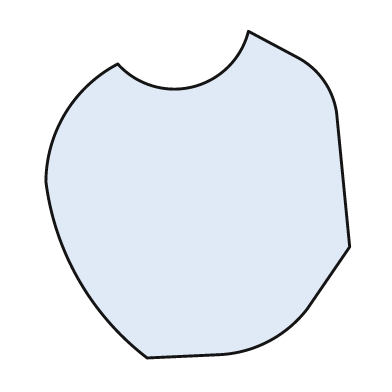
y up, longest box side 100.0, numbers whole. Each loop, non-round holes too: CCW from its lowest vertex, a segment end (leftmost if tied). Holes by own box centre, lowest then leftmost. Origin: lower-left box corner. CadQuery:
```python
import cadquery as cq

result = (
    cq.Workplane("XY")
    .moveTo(31.0, 0.0)
    .lineTo(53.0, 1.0)
    .threePointArc((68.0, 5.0), (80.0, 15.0))
    .lineTo(93.0, 34.0)
    .lineTo(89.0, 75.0)
    .threePointArc((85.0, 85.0), (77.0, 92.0))
    .lineTo(62.0, 100.0)
    .threePointArc((45.0, 83.0), (22.0, 90.0))
    .threePointArc((6.0, 75.0), (0.0, 54.0))
    .threePointArc((10.0, 24.0), (31.0, 0.0))
    .close()
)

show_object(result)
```